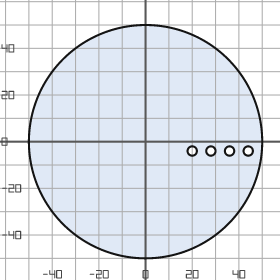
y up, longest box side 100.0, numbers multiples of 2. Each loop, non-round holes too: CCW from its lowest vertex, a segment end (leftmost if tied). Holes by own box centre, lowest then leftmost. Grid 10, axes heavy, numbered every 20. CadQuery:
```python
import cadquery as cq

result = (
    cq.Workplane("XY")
    .moveTo(0.0, 0.0)
    .circle(50.0)
    .moveTo(20.0, -4.0)
    .circle(2.0)
    .moveTo(28.0, -4.0)
    .circle(2.0)
    .moveTo(36.0, -4.0)
    .circle(2.0)
    .moveTo(44.0, -4.0)
    .circle(2.0)
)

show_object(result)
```